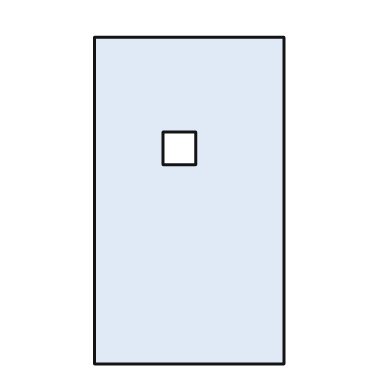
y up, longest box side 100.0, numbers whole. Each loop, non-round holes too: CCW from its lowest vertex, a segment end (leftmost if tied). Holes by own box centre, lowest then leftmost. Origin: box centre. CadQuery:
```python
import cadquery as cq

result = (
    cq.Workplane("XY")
    .moveTo(-29.0, -50.0)
    .lineTo(29.0, -50.0)
    .lineTo(29.0, 50.0)
    .lineTo(-29.0, 50.0)
    .close()
    .moveTo(-8.0, 11.0)
    .lineTo(2.0, 11.0)
    .lineTo(2.0, 21.0)
    .lineTo(-8.0, 21.0)
    .close()
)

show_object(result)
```